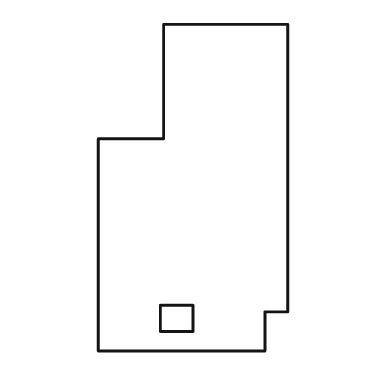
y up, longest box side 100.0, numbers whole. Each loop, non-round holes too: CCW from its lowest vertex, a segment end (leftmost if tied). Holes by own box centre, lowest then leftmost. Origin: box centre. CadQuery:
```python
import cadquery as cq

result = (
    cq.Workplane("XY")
    .moveTo(-29.0, -50.0)
    .lineTo(22.0, -50.0)
    .lineTo(22.0, -38.0)
    .lineTo(29.0, -38.0)
    .lineTo(29.0, 50.0)
    .lineTo(-9.0, 50.0)
    .lineTo(-9.0, 15.0)
    .lineTo(-29.0, 15.0)
    .close()
    .moveTo(-10.0, -44.0)
    .lineTo(0.0, -44.0)
    .lineTo(0.0, -36.0)
    .lineTo(-10.0, -36.0)
    .close()
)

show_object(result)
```